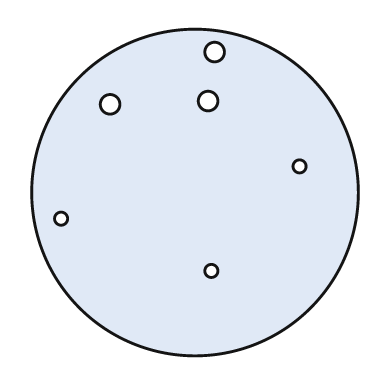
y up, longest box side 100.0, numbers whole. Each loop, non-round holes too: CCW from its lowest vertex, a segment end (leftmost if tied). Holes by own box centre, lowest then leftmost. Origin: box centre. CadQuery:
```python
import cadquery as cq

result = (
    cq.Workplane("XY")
    .moveTo(0.0, 0.0)
    .circle(50.0)
    .moveTo(5.0, -24.0)
    .circle(2.0)
    .moveTo(-41.0, -8.0)
    .circle(2.0)
    .moveTo(32.0, 8.0)
    .circle(2.0)
    .moveTo(-26.0, 27.0)
    .circle(3.0)
    .moveTo(4.0, 28.0)
    .circle(3.0)
    .moveTo(6.0, 43.0)
    .circle(3.0)
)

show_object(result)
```